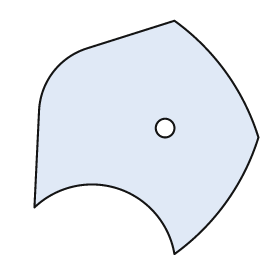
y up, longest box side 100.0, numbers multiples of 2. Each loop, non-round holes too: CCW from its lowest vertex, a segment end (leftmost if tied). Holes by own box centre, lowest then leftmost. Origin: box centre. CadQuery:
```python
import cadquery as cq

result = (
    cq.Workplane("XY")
    .moveTo(12.0, -50.0)
    .threePointArc((34.0, -28.0), (48.0, 0.0))
    .threePointArc((34.0, 28.0), (12.0, 50.0))
    .lineTo(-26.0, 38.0)
    .threePointArc((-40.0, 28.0), (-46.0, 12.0))
    .lineTo(-48.0, -30.0)
    .threePointArc((-12.0, -22.0), (12.0, -50.0))
    .close()
    .moveTo(8.0, 4.0)
    .circle(4.0)
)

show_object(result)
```